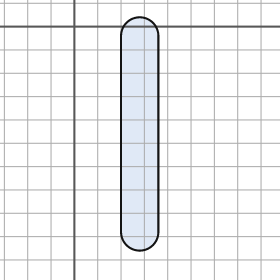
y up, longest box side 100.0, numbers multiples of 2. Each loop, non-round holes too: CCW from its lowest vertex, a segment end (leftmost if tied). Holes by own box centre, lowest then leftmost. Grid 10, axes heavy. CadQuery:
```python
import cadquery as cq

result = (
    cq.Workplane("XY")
    .moveTo(20.0, -88.0)
    .threePointArc((28.0, -96.0), (36.0, -88.0))
    .lineTo(36.0, -4.0)
    .threePointArc((28.0, 4.0), (20.0, -4.0))
    .close()
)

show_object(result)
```